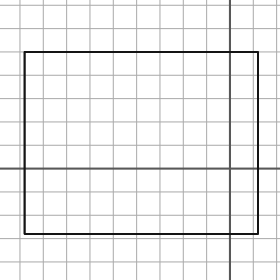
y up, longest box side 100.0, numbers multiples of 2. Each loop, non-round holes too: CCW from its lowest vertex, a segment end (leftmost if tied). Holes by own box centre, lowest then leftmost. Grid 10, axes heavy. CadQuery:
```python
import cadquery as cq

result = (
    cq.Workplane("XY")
    .moveTo(-88.0, -28.0)
    .lineTo(12.0, -28.0)
    .lineTo(12.0, 50.0)
    .lineTo(-88.0, 50.0)
    .close()
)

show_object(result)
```